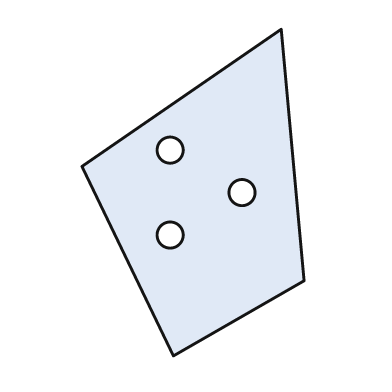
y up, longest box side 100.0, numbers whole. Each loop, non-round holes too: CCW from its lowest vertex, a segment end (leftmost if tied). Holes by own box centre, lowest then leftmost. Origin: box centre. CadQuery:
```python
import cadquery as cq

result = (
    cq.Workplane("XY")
    .moveTo(-6.0, -50.0)
    .lineTo(34.0, -27.0)
    .lineTo(27.0, 50.0)
    .lineTo(-34.0, 8.0)
    .close()
    .moveTo(-7.0, -13.0)
    .circle(4.0)
    .moveTo(15.0, 0.0)
    .circle(4.0)
    .moveTo(-7.0, 13.0)
    .circle(4.0)
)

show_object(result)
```